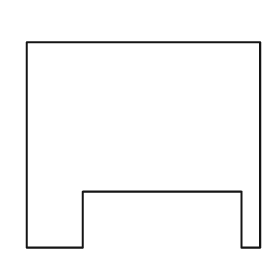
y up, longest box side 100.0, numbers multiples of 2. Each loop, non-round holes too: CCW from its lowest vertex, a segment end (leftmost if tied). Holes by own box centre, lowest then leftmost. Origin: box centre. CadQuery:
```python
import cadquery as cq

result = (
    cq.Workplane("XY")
    .moveTo(-50.0, -44.0)
    .lineTo(-26.0, -44.0)
    .lineTo(-26.0, -20.0)
    .lineTo(42.0, -20.0)
    .lineTo(42.0, -44.0)
    .lineTo(50.0, -44.0)
    .lineTo(50.0, 44.0)
    .lineTo(-50.0, 44.0)
    .close()
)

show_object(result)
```